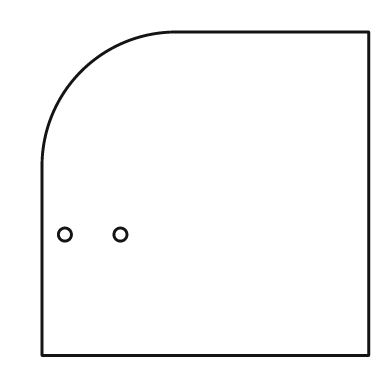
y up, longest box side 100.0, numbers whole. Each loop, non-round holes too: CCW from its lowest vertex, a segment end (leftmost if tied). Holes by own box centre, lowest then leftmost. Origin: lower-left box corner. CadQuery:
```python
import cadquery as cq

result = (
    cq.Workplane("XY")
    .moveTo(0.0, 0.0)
    .lineTo(100.0, 0.0)
    .lineTo(100.0, 99.0)
    .lineTo(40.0, 99.0)
    .threePointArc((12.0, 87.0), (0.0, 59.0))
    .close()
    .moveTo(7.0, 37.0)
    .circle(2.0)
    .moveTo(24.0, 37.0)
    .circle(2.0)
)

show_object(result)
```